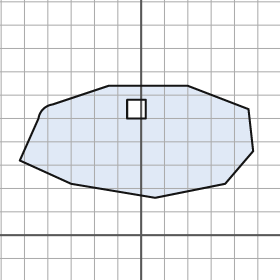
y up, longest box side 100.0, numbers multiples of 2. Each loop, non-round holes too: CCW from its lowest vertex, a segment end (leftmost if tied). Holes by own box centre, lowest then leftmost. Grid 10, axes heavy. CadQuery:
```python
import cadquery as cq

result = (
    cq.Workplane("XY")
    .moveTo(6.0, 16.0)
    .lineTo(36.0, 22.0)
    .lineTo(48.0, 36.0)
    .lineTo(46.0, 54.0)
    .lineTo(20.0, 64.0)
    .lineTo(-14.0, 64.0)
    .lineTo(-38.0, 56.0)
    .threePointArc((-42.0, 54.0), (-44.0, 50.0))
    .lineTo(-52.0, 32.0)
    .lineTo(-30.0, 22.0)
    .close()
    .moveTo(-6.0, 50.0)
    .lineTo(2.0, 50.0)
    .lineTo(2.0, 58.0)
    .lineTo(-6.0, 58.0)
    .close()
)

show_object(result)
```